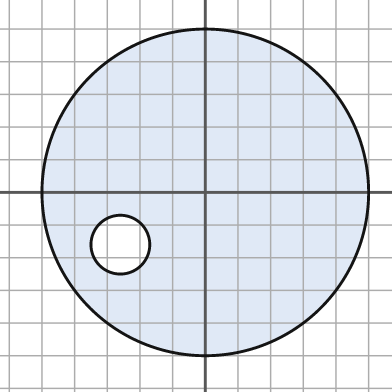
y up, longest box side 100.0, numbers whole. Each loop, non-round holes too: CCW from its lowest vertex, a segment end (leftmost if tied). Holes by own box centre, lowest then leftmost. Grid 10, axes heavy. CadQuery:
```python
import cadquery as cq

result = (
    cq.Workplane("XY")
    .moveTo(0.0, 0.0)
    .circle(50.0)
    .moveTo(-26.0, -16.0)
    .circle(9.0)
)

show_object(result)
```